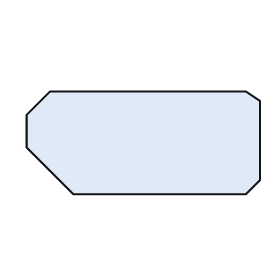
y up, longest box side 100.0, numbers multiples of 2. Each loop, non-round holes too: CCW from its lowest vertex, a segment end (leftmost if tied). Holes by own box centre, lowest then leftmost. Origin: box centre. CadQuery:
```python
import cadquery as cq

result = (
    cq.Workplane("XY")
    .moveTo(-30.0, -22.0)
    .lineTo(44.0, -22.0)
    .lineTo(50.0, -16.0)
    .lineTo(50.0, 18.0)
    .lineTo(44.0, 22.0)
    .lineTo(-40.0, 22.0)
    .lineTo(-50.0, 12.0)
    .lineTo(-50.0, -2.0)
    .close()
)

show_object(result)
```